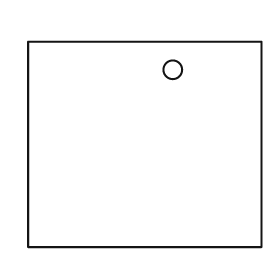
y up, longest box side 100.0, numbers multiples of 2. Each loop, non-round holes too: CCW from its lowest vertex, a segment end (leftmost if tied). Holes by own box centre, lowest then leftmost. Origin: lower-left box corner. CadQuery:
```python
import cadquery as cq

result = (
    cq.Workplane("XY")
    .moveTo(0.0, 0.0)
    .lineTo(100.0, 0.0)
    .lineTo(100.0, 88.0)
    .lineTo(0.0, 88.0)
    .close()
    .moveTo(62.0, 76.0)
    .circle(4.0)
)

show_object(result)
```